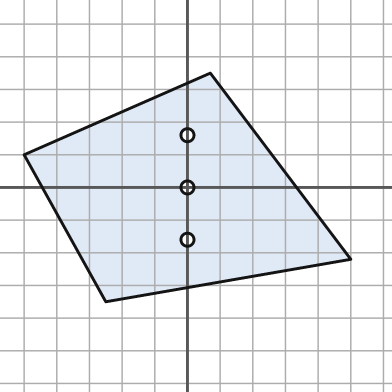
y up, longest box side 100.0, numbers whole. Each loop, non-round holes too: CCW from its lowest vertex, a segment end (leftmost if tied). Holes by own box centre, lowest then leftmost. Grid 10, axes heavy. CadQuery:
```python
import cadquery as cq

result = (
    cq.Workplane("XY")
    .moveTo(-25.0, -35.0)
    .lineTo(50.0, -22.0)
    .lineTo(7.0, 35.0)
    .lineTo(-50.0, 10.0)
    .close()
    .moveTo(0.0, -16.0)
    .circle(2.0)
    .moveTo(0.0, 0.0)
    .circle(2.0)
    .moveTo(0.0, 16.0)
    .circle(2.0)
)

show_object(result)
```